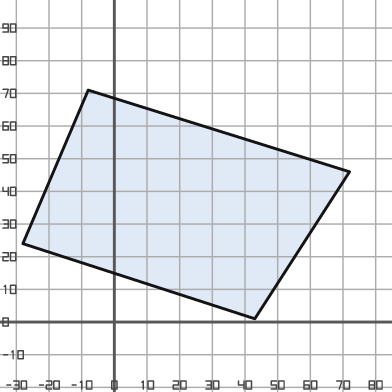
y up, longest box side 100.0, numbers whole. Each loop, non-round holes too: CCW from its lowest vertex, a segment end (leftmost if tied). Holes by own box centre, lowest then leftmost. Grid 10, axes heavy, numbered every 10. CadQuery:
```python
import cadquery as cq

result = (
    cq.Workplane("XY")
    .moveTo(43.0, 1.0)
    .lineTo(72.0, 46.0)
    .lineTo(-8.0, 71.0)
    .lineTo(-28.0, 24.0)
    .close()
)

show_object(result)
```